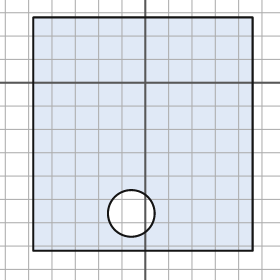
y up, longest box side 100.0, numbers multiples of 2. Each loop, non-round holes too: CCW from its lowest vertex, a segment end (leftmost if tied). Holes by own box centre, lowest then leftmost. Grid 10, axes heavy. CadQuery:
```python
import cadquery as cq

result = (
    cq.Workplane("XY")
    .moveTo(-48.0, -72.0)
    .lineTo(46.0, -72.0)
    .lineTo(46.0, 28.0)
    .lineTo(-48.0, 28.0)
    .close()
    .moveTo(-6.0, -56.0)
    .circle(10.0)
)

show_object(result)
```